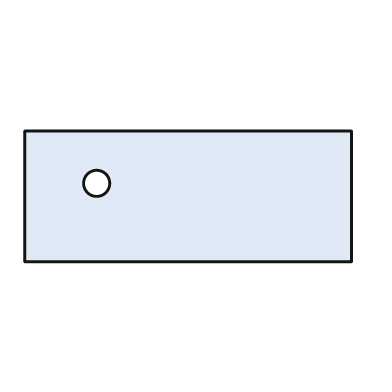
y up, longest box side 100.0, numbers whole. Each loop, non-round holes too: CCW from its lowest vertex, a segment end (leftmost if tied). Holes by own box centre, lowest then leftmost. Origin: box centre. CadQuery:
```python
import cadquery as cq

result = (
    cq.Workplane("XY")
    .moveTo(-50.0, -20.0)
    .lineTo(50.0, -20.0)
    .lineTo(50.0, 20.0)
    .lineTo(-50.0, 20.0)
    .close()
    .moveTo(-28.0, 4.0)
    .circle(4.0)
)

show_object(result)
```